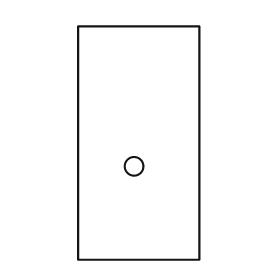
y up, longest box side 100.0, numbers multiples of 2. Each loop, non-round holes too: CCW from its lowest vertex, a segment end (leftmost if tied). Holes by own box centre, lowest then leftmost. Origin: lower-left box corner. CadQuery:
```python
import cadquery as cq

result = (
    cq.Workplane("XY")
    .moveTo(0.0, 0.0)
    .lineTo(52.0, 0.0)
    .lineTo(52.0, 100.0)
    .lineTo(0.0, 100.0)
    .close()
    .moveTo(24.0, 40.0)
    .circle(4.0)
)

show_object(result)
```